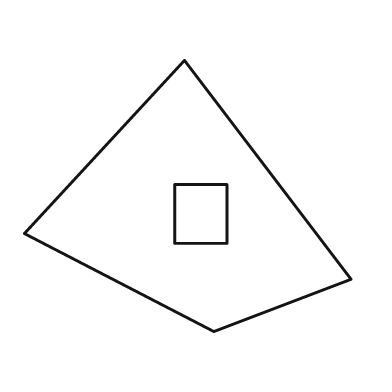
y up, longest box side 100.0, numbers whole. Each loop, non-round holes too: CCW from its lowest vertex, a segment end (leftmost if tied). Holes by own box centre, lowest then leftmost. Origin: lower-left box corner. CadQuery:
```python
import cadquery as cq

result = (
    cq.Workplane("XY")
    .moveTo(58.0, 0.0)
    .lineTo(100.0, 16.0)
    .lineTo(49.0, 83.0)
    .lineTo(0.0, 30.0)
    .close()
    .moveTo(46.0, 27.0)
    .lineTo(62.0, 27.0)
    .lineTo(62.0, 45.0)
    .lineTo(46.0, 45.0)
    .close()
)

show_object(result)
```